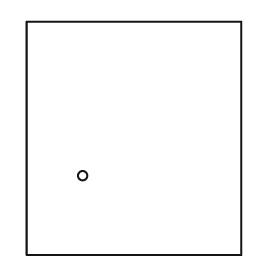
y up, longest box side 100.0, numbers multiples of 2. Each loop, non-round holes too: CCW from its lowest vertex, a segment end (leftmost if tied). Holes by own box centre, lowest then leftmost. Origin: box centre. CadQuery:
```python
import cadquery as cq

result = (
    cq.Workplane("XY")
    .moveTo(-46.0, -50.0)
    .lineTo(46.0, -50.0)
    .lineTo(46.0, 50.0)
    .lineTo(-46.0, 50.0)
    .close()
    .moveTo(-22.0, -16.0)
    .circle(2.0)
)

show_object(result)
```